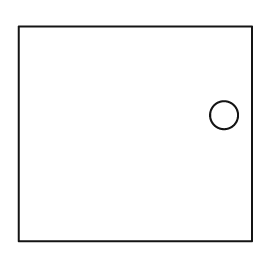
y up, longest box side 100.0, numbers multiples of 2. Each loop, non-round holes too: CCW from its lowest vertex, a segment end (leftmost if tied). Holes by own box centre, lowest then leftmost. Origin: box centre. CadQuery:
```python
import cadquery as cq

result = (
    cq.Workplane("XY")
    .moveTo(-50.0, -46.0)
    .lineTo(50.0, -46.0)
    .lineTo(50.0, 46.0)
    .lineTo(-50.0, 46.0)
    .close()
    .moveTo(38.0, 8.0)
    .circle(6.0)
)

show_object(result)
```